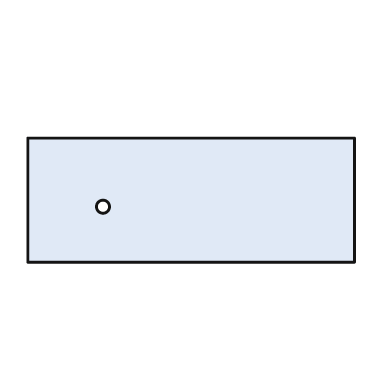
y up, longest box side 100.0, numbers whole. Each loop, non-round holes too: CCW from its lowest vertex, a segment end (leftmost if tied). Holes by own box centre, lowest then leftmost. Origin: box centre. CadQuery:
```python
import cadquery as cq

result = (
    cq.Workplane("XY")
    .moveTo(-50.0, -19.0)
    .lineTo(50.0, -19.0)
    .lineTo(50.0, 19.0)
    .lineTo(-50.0, 19.0)
    .close()
    .moveTo(-27.0, -2.0)
    .circle(2.0)
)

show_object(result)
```